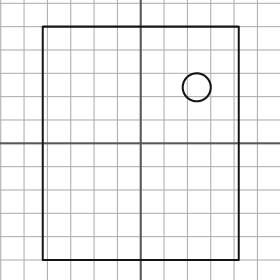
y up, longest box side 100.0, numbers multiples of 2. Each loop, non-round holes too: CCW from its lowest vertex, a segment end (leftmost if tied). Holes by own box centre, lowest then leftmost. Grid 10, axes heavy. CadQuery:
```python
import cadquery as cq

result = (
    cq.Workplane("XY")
    .moveTo(-42.0, -50.0)
    .lineTo(42.0, -50.0)
    .lineTo(42.0, 50.0)
    .lineTo(-42.0, 50.0)
    .close()
    .moveTo(24.0, 24.0)
    .circle(6.0)
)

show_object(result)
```